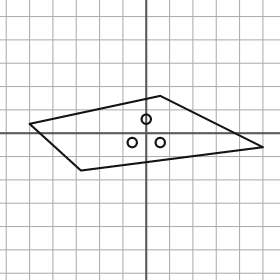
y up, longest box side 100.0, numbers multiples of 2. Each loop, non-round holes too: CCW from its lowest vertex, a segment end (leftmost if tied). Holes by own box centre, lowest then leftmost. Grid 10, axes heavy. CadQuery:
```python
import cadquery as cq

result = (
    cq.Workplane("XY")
    .moveTo(-28.0, -16.0)
    .lineTo(50.0, -6.0)
    .lineTo(6.0, 16.0)
    .lineTo(-50.0, 4.0)
    .close()
    .moveTo(-6.0, -4.0)
    .circle(2.0)
    .moveTo(6.0, -4.0)
    .circle(2.0)
    .moveTo(0.0, 6.0)
    .circle(2.0)
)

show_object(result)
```